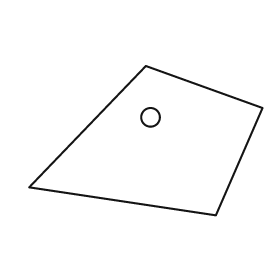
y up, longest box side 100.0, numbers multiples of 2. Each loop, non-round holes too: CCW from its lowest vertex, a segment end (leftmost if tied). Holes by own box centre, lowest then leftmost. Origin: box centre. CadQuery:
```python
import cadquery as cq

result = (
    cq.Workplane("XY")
    .moveTo(30.0, -32.0)
    .lineTo(50.0, 14.0)
    .lineTo(0.0, 32.0)
    .lineTo(-50.0, -20.0)
    .close()
    .moveTo(2.0, 10.0)
    .circle(4.0)
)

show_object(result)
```